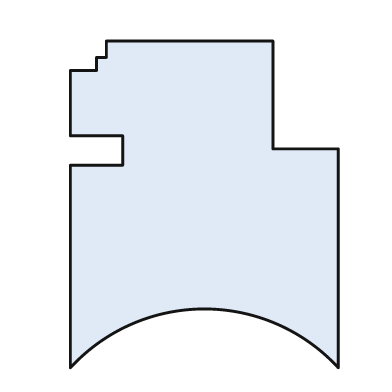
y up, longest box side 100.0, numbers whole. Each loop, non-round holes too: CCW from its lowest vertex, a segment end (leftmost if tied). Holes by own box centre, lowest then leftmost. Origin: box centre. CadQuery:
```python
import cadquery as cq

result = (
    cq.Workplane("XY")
    .moveTo(-41.0, -50.0)
    .threePointArc((0.0, -32.0), (41.0, -50.0))
    .lineTo(41.0, 17.0)
    .lineTo(21.0, 17.0)
    .lineTo(21.0, 50.0)
    .lineTo(-30.0, 50.0)
    .lineTo(-30.0, 45.0)
    .lineTo(-33.0, 45.0)
    .lineTo(-33.0, 41.0)
    .lineTo(-41.0, 41.0)
    .lineTo(-41.0, 21.0)
    .lineTo(-25.0, 21.0)
    .lineTo(-25.0, 12.0)
    .lineTo(-41.0, 12.0)
    .close()
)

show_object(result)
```